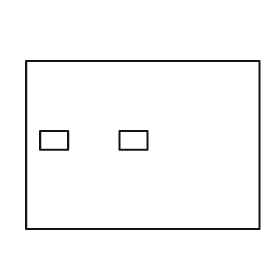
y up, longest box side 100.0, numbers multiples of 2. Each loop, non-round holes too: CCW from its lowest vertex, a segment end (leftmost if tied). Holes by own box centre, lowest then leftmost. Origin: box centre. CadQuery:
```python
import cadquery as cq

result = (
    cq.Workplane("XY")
    .moveTo(-50.0, -36.0)
    .lineTo(50.0, -36.0)
    .lineTo(50.0, 36.0)
    .lineTo(-50.0, 36.0)
    .close()
    .moveTo(-44.0, -2.0)
    .lineTo(-32.0, -2.0)
    .lineTo(-32.0, 6.0)
    .lineTo(-44.0, 6.0)
    .close()
    .moveTo(-10.0, -2.0)
    .lineTo(2.0, -2.0)
    .lineTo(2.0, 6.0)
    .lineTo(-10.0, 6.0)
    .close()
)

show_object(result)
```